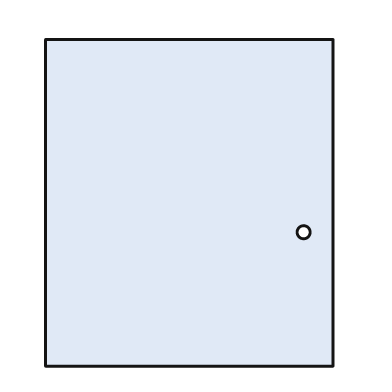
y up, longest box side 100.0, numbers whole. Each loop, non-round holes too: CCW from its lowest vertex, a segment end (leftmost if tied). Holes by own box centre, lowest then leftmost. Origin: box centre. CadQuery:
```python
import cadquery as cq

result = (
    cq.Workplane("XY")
    .moveTo(-44.0, -50.0)
    .lineTo(44.0, -50.0)
    .lineTo(44.0, 50.0)
    .lineTo(-44.0, 50.0)
    .close()
    .moveTo(35.0, -9.0)
    .circle(2.0)
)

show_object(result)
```